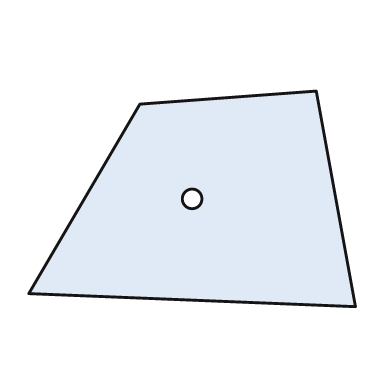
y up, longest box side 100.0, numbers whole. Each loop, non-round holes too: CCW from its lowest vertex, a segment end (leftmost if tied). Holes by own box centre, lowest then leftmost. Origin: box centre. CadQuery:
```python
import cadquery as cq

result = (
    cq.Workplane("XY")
    .moveTo(50.0, -33.0)
    .lineTo(38.0, 33.0)
    .lineTo(-16.0, 29.0)
    .lineTo(-50.0, -29.0)
    .close()
    .moveTo(0.0, 0.0)
    .circle(3.0)
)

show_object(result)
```